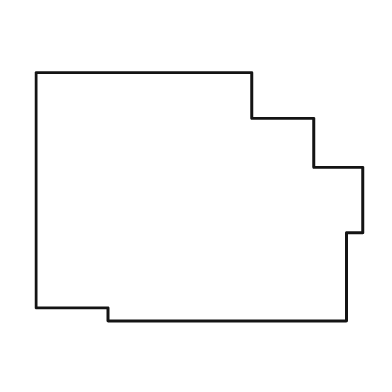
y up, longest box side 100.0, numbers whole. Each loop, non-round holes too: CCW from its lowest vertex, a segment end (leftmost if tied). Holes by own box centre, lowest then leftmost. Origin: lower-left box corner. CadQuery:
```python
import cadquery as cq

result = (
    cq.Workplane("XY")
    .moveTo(22.0, 0.0)
    .lineTo(95.0, 0.0)
    .lineTo(95.0, 27.0)
    .lineTo(100.0, 27.0)
    .lineTo(100.0, 47.0)
    .lineTo(85.0, 47.0)
    .lineTo(85.0, 62.0)
    .lineTo(66.0, 62.0)
    .lineTo(66.0, 76.0)
    .lineTo(0.0, 76.0)
    .lineTo(0.0, 4.0)
    .lineTo(22.0, 4.0)
    .close()
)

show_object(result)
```